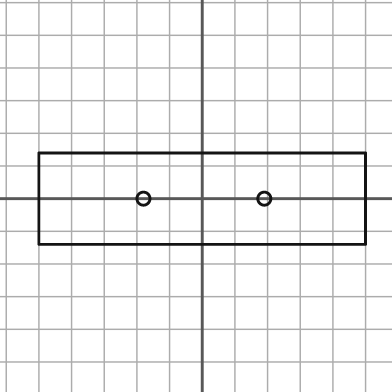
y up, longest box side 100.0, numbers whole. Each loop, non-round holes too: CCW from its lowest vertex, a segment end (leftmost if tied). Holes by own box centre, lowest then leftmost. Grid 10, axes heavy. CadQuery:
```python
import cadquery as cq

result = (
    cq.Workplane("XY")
    .moveTo(-50.0, -14.0)
    .lineTo(50.0, -14.0)
    .lineTo(50.0, 14.0)
    .lineTo(-50.0, 14.0)
    .close()
    .moveTo(-18.0, 0.0)
    .circle(2.0)
    .moveTo(19.0, 0.0)
    .circle(2.0)
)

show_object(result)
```